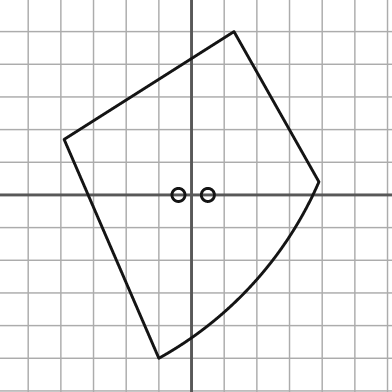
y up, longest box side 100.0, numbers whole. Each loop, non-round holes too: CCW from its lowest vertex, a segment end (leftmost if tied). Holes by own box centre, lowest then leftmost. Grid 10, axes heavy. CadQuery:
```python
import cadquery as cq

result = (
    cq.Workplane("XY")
    .moveTo(-10.0, -50.0)
    .threePointArc((19.0, -27.0), (39.0, 4.0))
    .lineTo(13.0, 50.0)
    .lineTo(-39.0, 17.0)
    .close()
    .moveTo(-4.0, 0.0)
    .circle(2.0)
    .moveTo(5.0, 0.0)
    .circle(2.0)
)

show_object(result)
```